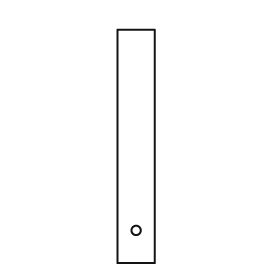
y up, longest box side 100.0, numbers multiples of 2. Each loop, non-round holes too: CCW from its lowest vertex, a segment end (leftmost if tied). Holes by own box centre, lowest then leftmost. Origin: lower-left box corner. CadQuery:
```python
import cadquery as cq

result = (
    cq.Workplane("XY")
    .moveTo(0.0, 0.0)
    .lineTo(16.0, 0.0)
    .lineTo(16.0, 100.0)
    .lineTo(0.0, 100.0)
    .close()
    .moveTo(8.0, 14.0)
    .circle(2.0)
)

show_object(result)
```